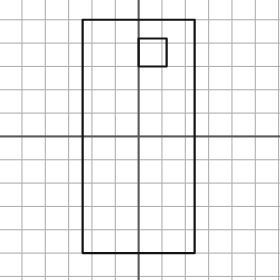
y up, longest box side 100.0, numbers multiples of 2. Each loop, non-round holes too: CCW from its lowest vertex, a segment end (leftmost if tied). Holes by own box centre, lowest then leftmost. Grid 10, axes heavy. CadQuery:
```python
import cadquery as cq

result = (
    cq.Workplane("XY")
    .moveTo(-24.0, -50.0)
    .lineTo(24.0, -50.0)
    .lineTo(24.0, 50.0)
    .lineTo(-24.0, 50.0)
    .close()
    .moveTo(0.0, 30.0)
    .lineTo(12.0, 30.0)
    .lineTo(12.0, 42.0)
    .lineTo(0.0, 42.0)
    .close()
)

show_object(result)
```